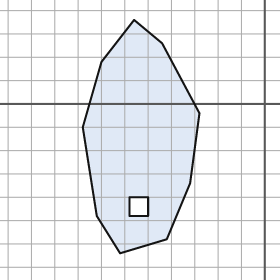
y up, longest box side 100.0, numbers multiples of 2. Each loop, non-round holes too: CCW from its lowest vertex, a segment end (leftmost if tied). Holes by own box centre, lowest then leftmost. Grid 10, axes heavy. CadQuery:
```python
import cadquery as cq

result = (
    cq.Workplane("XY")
    .moveTo(-62.0, -64.0)
    .lineTo(-42.0, -58.0)
    .lineTo(-32.0, -34.0)
    .lineTo(-28.0, -4.0)
    .lineTo(-44.0, 26.0)
    .lineTo(-56.0, 36.0)
    .lineTo(-70.0, 18.0)
    .lineTo(-78.0, -10.0)
    .lineTo(-72.0, -48.0)
    .close()
    .moveTo(-58.0, -48.0)
    .lineTo(-50.0, -48.0)
    .lineTo(-50.0, -40.0)
    .lineTo(-58.0, -40.0)
    .close()
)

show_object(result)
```